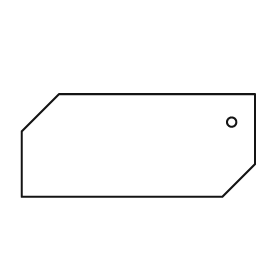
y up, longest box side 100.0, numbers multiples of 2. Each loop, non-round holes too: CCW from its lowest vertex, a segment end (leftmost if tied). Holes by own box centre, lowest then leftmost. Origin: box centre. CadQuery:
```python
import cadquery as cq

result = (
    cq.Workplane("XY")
    .moveTo(-50.0, -22.0)
    .lineTo(36.0, -22.0)
    .lineTo(50.0, -8.0)
    .lineTo(50.0, 22.0)
    .lineTo(-34.0, 22.0)
    .lineTo(-50.0, 6.0)
    .close()
    .moveTo(40.0, 10.0)
    .circle(2.0)
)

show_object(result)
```